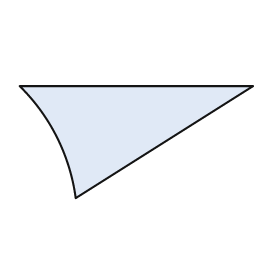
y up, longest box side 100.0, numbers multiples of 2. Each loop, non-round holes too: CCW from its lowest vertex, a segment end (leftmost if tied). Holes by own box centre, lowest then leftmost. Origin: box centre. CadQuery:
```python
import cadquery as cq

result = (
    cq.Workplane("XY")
    .moveTo(-26.0, -24.0)
    .lineTo(50.0, 24.0)
    .lineTo(-50.0, 24.0)
    .threePointArc((-34.0, 2.0), (-26.0, -24.0))
    .close()
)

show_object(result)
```